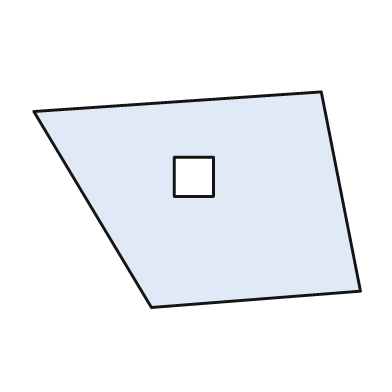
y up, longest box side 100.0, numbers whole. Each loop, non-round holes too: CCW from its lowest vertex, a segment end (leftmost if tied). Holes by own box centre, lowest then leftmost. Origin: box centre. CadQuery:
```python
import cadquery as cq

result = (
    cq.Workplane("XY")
    .moveTo(-14.0, -33.0)
    .lineTo(50.0, -28.0)
    .lineTo(38.0, 33.0)
    .lineTo(-50.0, 27.0)
    .close()
    .moveTo(-7.0, 1.0)
    .lineTo(5.0, 1.0)
    .lineTo(5.0, 13.0)
    .lineTo(-7.0, 13.0)
    .close()
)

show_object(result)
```